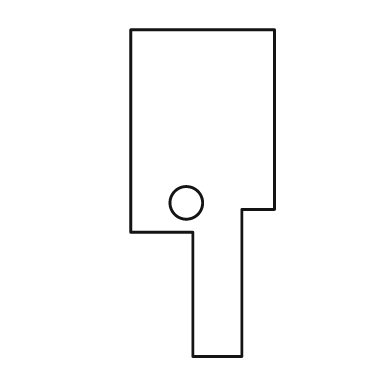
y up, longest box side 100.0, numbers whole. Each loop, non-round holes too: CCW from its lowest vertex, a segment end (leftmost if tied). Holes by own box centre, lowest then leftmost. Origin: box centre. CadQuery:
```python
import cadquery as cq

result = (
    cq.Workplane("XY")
    .moveTo(-3.0, -50.0)
    .lineTo(12.0, -50.0)
    .lineTo(12.0, -5.0)
    .lineTo(22.0, -5.0)
    .lineTo(22.0, 50.0)
    .lineTo(-22.0, 50.0)
    .lineTo(-22.0, -12.0)
    .lineTo(-3.0, -12.0)
    .close()
    .moveTo(-5.0, -3.0)
    .circle(5.0)
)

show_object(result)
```